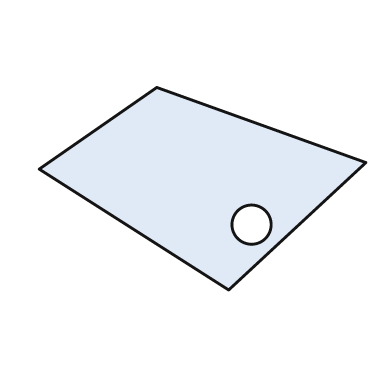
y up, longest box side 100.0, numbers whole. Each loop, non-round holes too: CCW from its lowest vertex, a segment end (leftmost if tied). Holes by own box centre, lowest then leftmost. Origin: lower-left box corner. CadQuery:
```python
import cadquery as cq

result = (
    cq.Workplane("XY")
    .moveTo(58.0, 0.0)
    .lineTo(100.0, 39.0)
    .lineTo(36.0, 62.0)
    .lineTo(0.0, 37.0)
    .close()
    .moveTo(65.0, 20.0)
    .circle(6.0)
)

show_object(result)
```